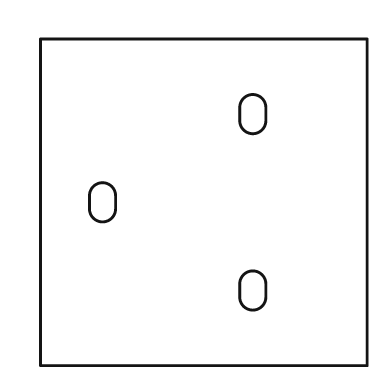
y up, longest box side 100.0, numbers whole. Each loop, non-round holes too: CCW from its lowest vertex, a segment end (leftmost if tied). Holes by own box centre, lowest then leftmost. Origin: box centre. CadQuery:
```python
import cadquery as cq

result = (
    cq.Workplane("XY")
    .moveTo(-50.0, -50.0)
    .lineTo(50.0, -50.0)
    .lineTo(50.0, 50.0)
    .lineTo(-50.0, 50.0)
    .close()
    .moveTo(11.0, -29.0)
    .threePointArc((15.0, -33.0), (19.0, -29.0))
    .lineTo(19.0, -25.0)
    .threePointArc((15.0, -21.0), (11.0, -25.0))
    .close()
    .moveTo(-35.0, -2.0)
    .threePointArc((-31.0, -6.0), (-27.0, -2.0))
    .lineTo(-27.0, 2.0)
    .threePointArc((-31.0, 6.0), (-35.0, 2.0))
    .close()
    .moveTo(11.0, 25.0)
    .threePointArc((15.0, 21.0), (19.0, 25.0))
    .lineTo(19.0, 29.0)
    .threePointArc((15.0, 33.0), (11.0, 29.0))
    .close()
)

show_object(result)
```